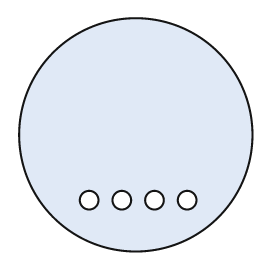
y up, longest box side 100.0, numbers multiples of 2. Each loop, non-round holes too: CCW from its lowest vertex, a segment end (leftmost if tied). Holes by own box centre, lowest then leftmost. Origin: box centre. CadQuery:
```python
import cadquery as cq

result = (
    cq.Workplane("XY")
    .moveTo(0.0, 0.0)
    .circle(50.0)
    .moveTo(-20.0, -28.0)
    .circle(4.0)
    .moveTo(-6.0, -28.0)
    .circle(4.0)
    .moveTo(8.0, -28.0)
    .circle(4.0)
    .moveTo(22.0, -28.0)
    .circle(4.0)
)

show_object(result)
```